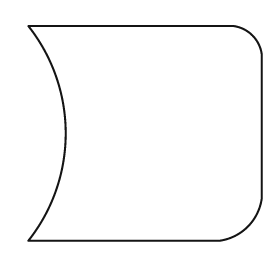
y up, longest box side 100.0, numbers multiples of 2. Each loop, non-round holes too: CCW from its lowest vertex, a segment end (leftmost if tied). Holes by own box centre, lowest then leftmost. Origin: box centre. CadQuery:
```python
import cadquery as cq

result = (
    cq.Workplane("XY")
    .moveTo(-50.0, -46.0)
    .lineTo(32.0, -46.0)
    .threePointArc((44.0, -40.0), (50.0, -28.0))
    .lineTo(50.0, 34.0)
    .threePointArc((46.0, 42.0), (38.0, 46.0))
    .lineTo(-50.0, 46.0)
    .threePointArc((-34.0, 0.0), (-50.0, -46.0))
    .close()
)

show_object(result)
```